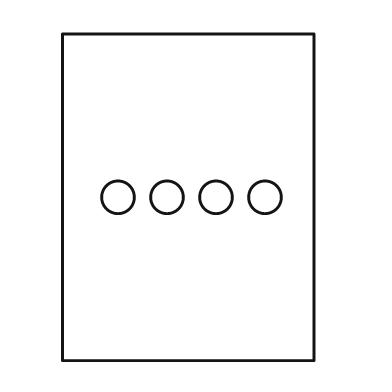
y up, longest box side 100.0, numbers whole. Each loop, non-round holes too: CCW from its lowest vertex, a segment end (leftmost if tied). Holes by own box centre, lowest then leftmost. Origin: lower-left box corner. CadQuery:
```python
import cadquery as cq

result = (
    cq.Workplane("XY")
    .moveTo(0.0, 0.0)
    .lineTo(77.0, 0.0)
    .lineTo(77.0, 100.0)
    .lineTo(0.0, 100.0)
    .close()
    .moveTo(17.0, 50.0)
    .circle(5.0)
    .moveTo(32.0, 50.0)
    .circle(5.0)
    .moveTo(47.0, 50.0)
    .circle(5.0)
    .moveTo(62.0, 50.0)
    .circle(5.0)
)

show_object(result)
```